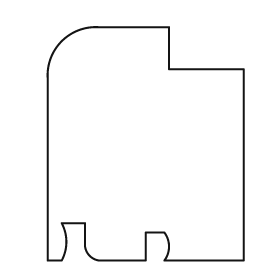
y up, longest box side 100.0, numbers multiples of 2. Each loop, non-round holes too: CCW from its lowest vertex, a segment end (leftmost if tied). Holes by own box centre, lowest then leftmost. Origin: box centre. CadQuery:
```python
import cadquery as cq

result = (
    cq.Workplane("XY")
    .moveTo(-42.0, -50.0)
    .lineTo(-36.0, -50.0)
    .threePointArc((-34.0, -42.0), (-36.0, -34.0))
    .lineTo(-26.0, -34.0)
    .lineTo(-26.0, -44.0)
    .threePointArc((-24.0, -48.0), (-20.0, -50.0))
    .lineTo(0.0, -50.0)
    .lineTo(0.0, -38.0)
    .lineTo(8.0, -38.0)
    .threePointArc((10.0, -44.0), (8.0, -50.0))
    .lineTo(42.0, -50.0)
    .lineTo(42.0, 32.0)
    .lineTo(10.0, 32.0)
    .lineTo(10.0, 50.0)
    .lineTo(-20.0, 50.0)
    .threePointArc((-36.0, 44.0), (-42.0, 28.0))
    .close()
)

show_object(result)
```